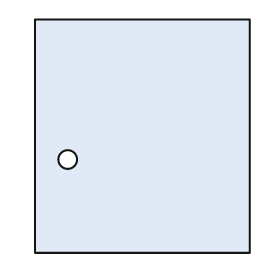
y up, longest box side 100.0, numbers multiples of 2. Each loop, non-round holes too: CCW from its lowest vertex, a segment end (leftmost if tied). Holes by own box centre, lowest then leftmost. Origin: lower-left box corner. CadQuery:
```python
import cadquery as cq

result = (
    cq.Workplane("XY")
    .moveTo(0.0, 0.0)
    .lineTo(92.0, 0.0)
    .lineTo(92.0, 100.0)
    .lineTo(0.0, 100.0)
    .close()
    .moveTo(14.0, 40.0)
    .circle(4.0)
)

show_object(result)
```